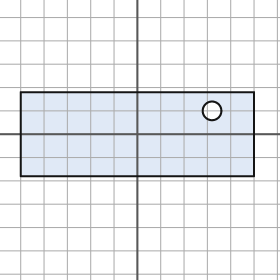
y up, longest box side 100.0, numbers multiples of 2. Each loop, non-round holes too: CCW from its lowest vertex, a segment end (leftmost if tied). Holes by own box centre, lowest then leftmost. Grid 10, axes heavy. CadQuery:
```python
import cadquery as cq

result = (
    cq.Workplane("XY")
    .moveTo(-50.0, -18.0)
    .lineTo(50.0, -18.0)
    .lineTo(50.0, 18.0)
    .lineTo(-50.0, 18.0)
    .close()
    .moveTo(32.0, 10.0)
    .circle(4.0)
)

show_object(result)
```